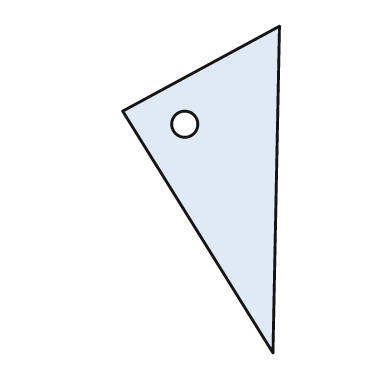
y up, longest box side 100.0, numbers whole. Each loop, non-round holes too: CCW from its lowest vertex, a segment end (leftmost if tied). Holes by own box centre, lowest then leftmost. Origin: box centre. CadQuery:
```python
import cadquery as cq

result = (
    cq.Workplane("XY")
    .moveTo(22.0, -50.0)
    .lineTo(24.0, 50.0)
    .lineTo(-24.0, 24.0)
    .close()
    .moveTo(-5.0, 20.0)
    .circle(4.0)
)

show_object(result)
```